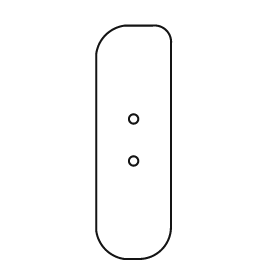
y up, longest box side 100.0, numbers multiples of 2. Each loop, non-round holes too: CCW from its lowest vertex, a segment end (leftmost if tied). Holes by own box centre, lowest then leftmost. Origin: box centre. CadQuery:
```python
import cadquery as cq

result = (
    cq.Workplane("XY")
    .moveTo(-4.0, -50.0)
    .lineTo(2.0, -50.0)
    .threePointArc((12.0, -46.0), (16.0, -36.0))
    .lineTo(16.0, 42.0)
    .threePointArc((14.0, 48.0), (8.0, 50.0))
    .lineTo(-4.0, 50.0)
    .threePointArc((-12.0, 46.0), (-16.0, 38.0))
    .lineTo(-16.0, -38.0)
    .threePointArc((-12.0, -46.0), (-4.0, -50.0))
    .close()
    .moveTo(0.0, -8.0)
    .circle(2.0)
    .moveTo(0.0, 10.0)
    .circle(2.0)
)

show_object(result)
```